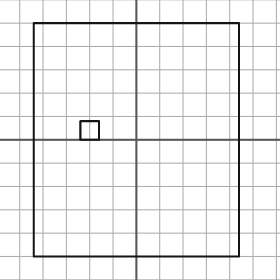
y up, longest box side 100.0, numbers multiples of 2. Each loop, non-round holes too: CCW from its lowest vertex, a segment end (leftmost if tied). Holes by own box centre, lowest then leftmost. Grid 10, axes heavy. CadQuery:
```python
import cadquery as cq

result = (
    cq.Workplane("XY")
    .moveTo(-44.0, -50.0)
    .lineTo(44.0, -50.0)
    .lineTo(44.0, 50.0)
    .lineTo(-44.0, 50.0)
    .close()
    .moveTo(-24.0, 0.0)
    .lineTo(-16.0, 0.0)
    .lineTo(-16.0, 8.0)
    .lineTo(-24.0, 8.0)
    .close()
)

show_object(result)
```